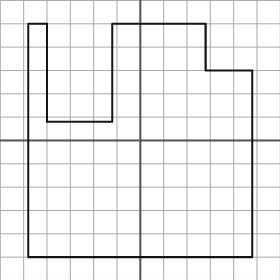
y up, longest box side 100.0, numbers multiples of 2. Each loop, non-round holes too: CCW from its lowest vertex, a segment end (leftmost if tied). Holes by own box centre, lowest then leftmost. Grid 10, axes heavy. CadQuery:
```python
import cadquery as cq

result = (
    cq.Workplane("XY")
    .moveTo(-48.0, -50.0)
    .lineTo(48.0, -50.0)
    .lineTo(48.0, 30.0)
    .lineTo(28.0, 30.0)
    .lineTo(28.0, 50.0)
    .lineTo(-12.0, 50.0)
    .lineTo(-12.0, 8.0)
    .lineTo(-40.0, 8.0)
    .lineTo(-40.0, 50.0)
    .lineTo(-48.0, 50.0)
    .close()
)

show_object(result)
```